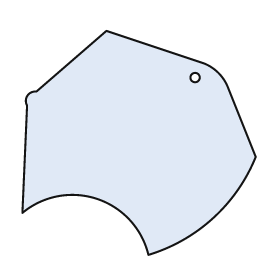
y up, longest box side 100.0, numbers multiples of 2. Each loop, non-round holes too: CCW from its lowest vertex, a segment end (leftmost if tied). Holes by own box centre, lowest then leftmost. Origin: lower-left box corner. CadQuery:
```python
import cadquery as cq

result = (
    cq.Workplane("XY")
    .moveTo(54.0, 0.0)
    .threePointArc((82.0, 16.0), (100.0, 42.0))
    .lineTo(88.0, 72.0)
    .threePointArc((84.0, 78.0), (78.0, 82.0))
    .lineTo(36.0, 96.0)
    .lineTo(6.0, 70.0)
    .threePointArc((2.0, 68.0), (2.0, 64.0))
    .lineTo(0.0, 18.0)
    .threePointArc((32.0, 24.0), (54.0, 0.0))
    .close()
    .moveTo(74.0, 76.0)
    .circle(2.0)
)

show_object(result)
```